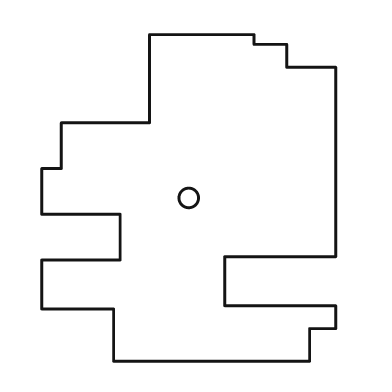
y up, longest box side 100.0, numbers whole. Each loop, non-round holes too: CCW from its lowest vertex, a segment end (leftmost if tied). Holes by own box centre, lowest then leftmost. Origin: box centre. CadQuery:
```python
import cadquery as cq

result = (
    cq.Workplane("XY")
    .moveTo(-23.0, -50.0)
    .lineTo(37.0, -50.0)
    .lineTo(37.0, -40.0)
    .lineTo(45.0, -40.0)
    .lineTo(45.0, -33.0)
    .lineTo(11.0, -33.0)
    .lineTo(11.0, -18.0)
    .lineTo(45.0, -18.0)
    .lineTo(45.0, 40.0)
    .lineTo(30.0, 40.0)
    .lineTo(30.0, 47.0)
    .lineTo(20.0, 47.0)
    .lineTo(20.0, 50.0)
    .lineTo(-12.0, 50.0)
    .lineTo(-12.0, 23.0)
    .lineTo(-39.0, 23.0)
    .lineTo(-39.0, 9.0)
    .lineTo(-45.0, 9.0)
    .lineTo(-45.0, -5.0)
    .lineTo(-21.0, -5.0)
    .lineTo(-21.0, -19.0)
    .lineTo(-45.0, -19.0)
    .lineTo(-45.0, -34.0)
    .lineTo(-23.0, -34.0)
    .close()
    .moveTo(0.0, 0.0)
    .circle(3.0)
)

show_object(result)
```